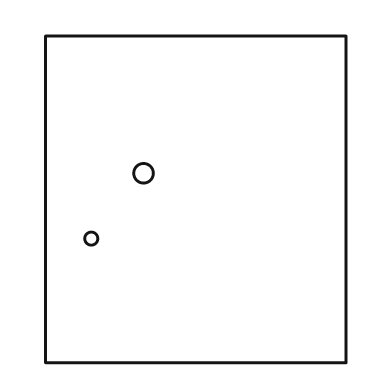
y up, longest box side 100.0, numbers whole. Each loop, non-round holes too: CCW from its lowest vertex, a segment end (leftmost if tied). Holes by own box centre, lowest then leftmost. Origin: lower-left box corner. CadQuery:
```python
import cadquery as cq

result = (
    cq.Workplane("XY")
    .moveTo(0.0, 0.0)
    .lineTo(92.0, 0.0)
    .lineTo(92.0, 100.0)
    .lineTo(0.0, 100.0)
    .close()
    .moveTo(14.0, 38.0)
    .circle(2.0)
    .moveTo(30.0, 58.0)
    .circle(3.0)
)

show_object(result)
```